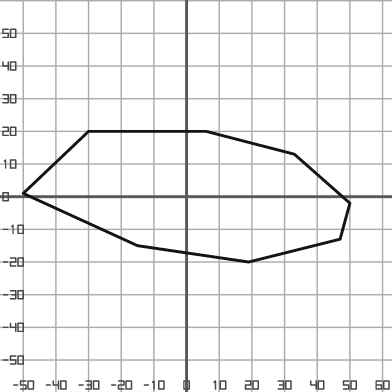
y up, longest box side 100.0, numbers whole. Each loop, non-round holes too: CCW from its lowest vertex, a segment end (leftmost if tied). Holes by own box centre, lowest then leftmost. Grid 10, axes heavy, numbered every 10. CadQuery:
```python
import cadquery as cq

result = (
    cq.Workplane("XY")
    .moveTo(19.0, -20.0)
    .lineTo(47.0, -13.0)
    .lineTo(50.0, -2.0)
    .lineTo(33.0, 13.0)
    .lineTo(6.0, 20.0)
    .lineTo(-30.0, 20.0)
    .lineTo(-50.0, 1.0)
    .lineTo(-15.0, -15.0)
    .close()
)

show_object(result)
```